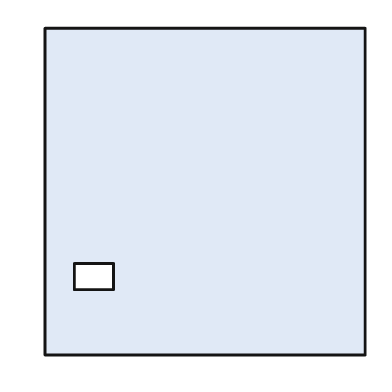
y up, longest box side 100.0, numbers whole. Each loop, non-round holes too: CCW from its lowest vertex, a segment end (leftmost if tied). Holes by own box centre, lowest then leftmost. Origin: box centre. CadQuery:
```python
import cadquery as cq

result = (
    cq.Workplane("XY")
    .moveTo(-49.0, -50.0)
    .lineTo(49.0, -50.0)
    .lineTo(49.0, 50.0)
    .lineTo(-49.0, 50.0)
    .close()
    .moveTo(-40.0, -30.0)
    .lineTo(-28.0, -30.0)
    .lineTo(-28.0, -22.0)
    .lineTo(-40.0, -22.0)
    .close()
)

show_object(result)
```